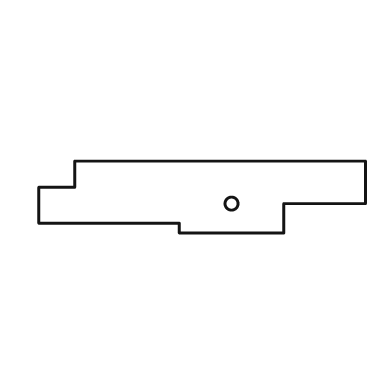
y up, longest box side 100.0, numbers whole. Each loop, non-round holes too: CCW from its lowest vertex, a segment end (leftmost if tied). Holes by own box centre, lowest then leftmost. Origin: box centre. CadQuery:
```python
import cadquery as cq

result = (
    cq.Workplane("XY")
    .moveTo(-7.0, -11.0)
    .lineTo(25.0, -11.0)
    .lineTo(25.0, -2.0)
    .lineTo(50.0, -2.0)
    .lineTo(50.0, 11.0)
    .lineTo(-39.0, 11.0)
    .lineTo(-39.0, 3.0)
    .lineTo(-50.0, 3.0)
    .lineTo(-50.0, -8.0)
    .lineTo(-7.0, -8.0)
    .close()
    .moveTo(9.0, -2.0)
    .circle(2.0)
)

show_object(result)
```